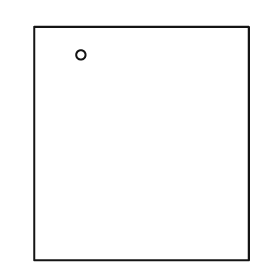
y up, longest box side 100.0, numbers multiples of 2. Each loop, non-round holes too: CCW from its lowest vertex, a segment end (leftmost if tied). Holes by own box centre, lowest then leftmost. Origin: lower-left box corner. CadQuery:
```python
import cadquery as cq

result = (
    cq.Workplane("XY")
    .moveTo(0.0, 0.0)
    .lineTo(92.0, 0.0)
    .lineTo(92.0, 100.0)
    .lineTo(0.0, 100.0)
    .close()
    .moveTo(20.0, 88.0)
    .circle(2.0)
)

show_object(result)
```